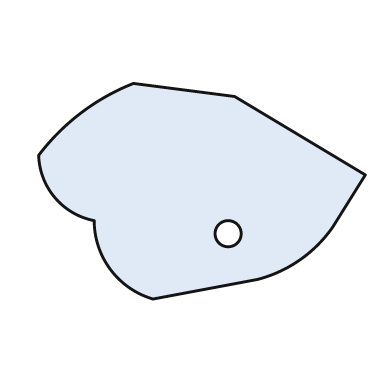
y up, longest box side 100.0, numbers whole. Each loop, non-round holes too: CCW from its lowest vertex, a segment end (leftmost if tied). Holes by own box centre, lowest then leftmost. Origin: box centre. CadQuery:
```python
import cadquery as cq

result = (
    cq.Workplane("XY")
    .moveTo(-15.0, -33.0)
    .lineTo(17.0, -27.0)
    .threePointArc((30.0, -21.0), (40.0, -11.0))
    .lineTo(50.0, 5.0)
    .lineTo(10.0, 29.0)
    .lineTo(-21.0, 33.0)
    .threePointArc((-37.0, 24.0), (-50.0, 11.0))
    .threePointArc((-45.0, -2.0), (-33.0, -9.0))
    .threePointArc((-28.0, -24.0), (-15.0, -33.0))
    .close()
    .moveTo(8.0, -13.0)
    .circle(4.0)
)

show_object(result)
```